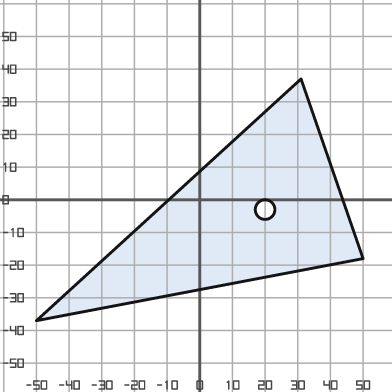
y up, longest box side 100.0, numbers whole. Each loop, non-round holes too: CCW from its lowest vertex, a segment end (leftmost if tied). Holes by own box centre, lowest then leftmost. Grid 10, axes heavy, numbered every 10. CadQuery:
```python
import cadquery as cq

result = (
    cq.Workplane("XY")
    .moveTo(-50.0, -37.0)
    .lineTo(50.0, -18.0)
    .lineTo(31.0, 37.0)
    .close()
    .moveTo(20.0, -3.0)
    .circle(3.0)
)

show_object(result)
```